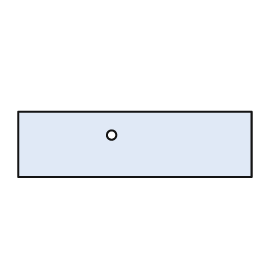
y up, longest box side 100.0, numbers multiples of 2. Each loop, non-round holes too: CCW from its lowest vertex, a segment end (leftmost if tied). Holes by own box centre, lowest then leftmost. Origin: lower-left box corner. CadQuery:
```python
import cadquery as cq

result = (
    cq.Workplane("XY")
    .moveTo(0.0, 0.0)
    .lineTo(100.0, 0.0)
    .lineTo(100.0, 28.0)
    .lineTo(0.0, 28.0)
    .close()
    .moveTo(40.0, 18.0)
    .circle(2.0)
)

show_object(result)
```